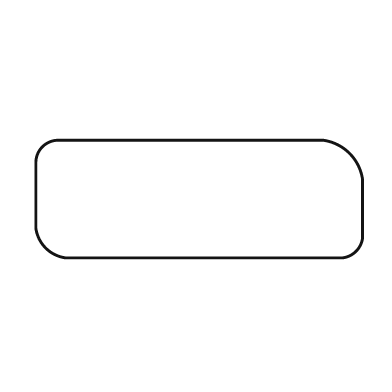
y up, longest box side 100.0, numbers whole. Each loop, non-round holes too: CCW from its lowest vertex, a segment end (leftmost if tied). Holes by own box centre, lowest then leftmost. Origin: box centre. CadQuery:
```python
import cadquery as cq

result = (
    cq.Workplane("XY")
    .moveTo(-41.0, -18.0)
    .lineTo(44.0, -18.0)
    .threePointArc((48.0, -16.0), (50.0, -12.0))
    .lineTo(50.0, 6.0)
    .threePointArc((46.0, 14.0), (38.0, 18.0))
    .lineTo(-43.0, 18.0)
    .threePointArc((-48.0, 16.0), (-50.0, 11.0))
    .lineTo(-50.0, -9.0)
    .threePointArc((-47.0, -15.0), (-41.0, -18.0))
    .close()
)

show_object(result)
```